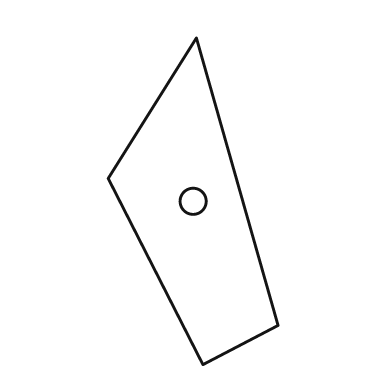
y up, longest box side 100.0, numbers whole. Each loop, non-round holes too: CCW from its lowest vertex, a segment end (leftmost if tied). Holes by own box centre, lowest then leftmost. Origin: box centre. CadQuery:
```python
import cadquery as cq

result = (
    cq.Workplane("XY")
    .moveTo(3.0, -50.0)
    .lineTo(26.0, -38.0)
    .lineTo(1.0, 50.0)
    .lineTo(-26.0, 7.0)
    .close()
    .moveTo(0.0, 0.0)
    .circle(4.0)
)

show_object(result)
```